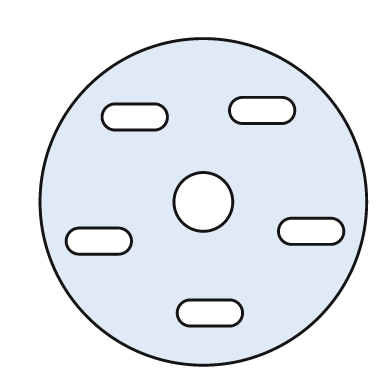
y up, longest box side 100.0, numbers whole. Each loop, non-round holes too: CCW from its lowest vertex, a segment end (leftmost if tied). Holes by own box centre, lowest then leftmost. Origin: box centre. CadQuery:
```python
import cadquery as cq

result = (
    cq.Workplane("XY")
    .moveTo(0.0, 0.0)
    .circle(50.0)
    .moveTo(-4.0, -38.0)
    .lineTo(8.0, -38.0)
    .threePointArc((12.0, -34.0), (8.0, -30.0))
    .lineTo(-4.0, -30.0)
    .threePointArc((-8.0, -34.0), (-4.0, -38.0))
    .close()
    .moveTo(-38.0, -16.0)
    .lineTo(-26.0, -16.0)
    .threePointArc((-22.0, -12.0), (-26.0, -8.0))
    .lineTo(-38.0, -8.0)
    .threePointArc((-42.0, -12.0), (-38.0, -16.0))
    .close()
    .moveTo(27.0, -13.0)
    .lineTo(39.0, -13.0)
    .threePointArc((43.0, -9.0), (39.0, -5.0))
    .lineTo(27.0, -5.0)
    .threePointArc((23.0, -9.0), (27.0, -13.0))
    .close()
    .moveTo(0.0, 0.0)
    .circle(9.0)
    .moveTo(-27.0, 22.0)
    .lineTo(-15.0, 22.0)
    .threePointArc((-11.0, 26.0), (-15.0, 30.0))
    .lineTo(-27.0, 30.0)
    .threePointArc((-31.0, 26.0), (-27.0, 22.0))
    .close()
    .moveTo(12.0, 24.0)
    .lineTo(24.0, 24.0)
    .threePointArc((28.0, 28.0), (24.0, 32.0))
    .lineTo(12.0, 32.0)
    .threePointArc((8.0, 28.0), (12.0, 24.0))
    .close()
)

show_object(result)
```